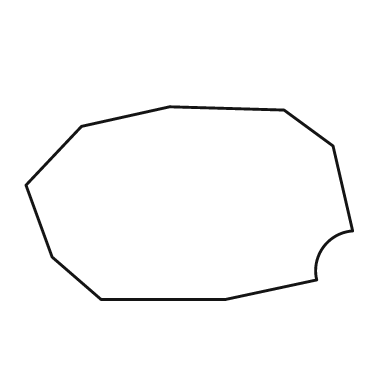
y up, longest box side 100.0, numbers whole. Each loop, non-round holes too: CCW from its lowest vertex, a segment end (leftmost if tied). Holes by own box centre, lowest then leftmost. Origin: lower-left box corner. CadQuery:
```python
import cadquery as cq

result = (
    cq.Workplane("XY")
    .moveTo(23.0, 0.0)
    .lineTo(61.0, 0.0)
    .lineTo(89.0, 6.0)
    .threePointArc((91.0, 16.0), (100.0, 21.0))
    .lineTo(94.0, 47.0)
    .lineTo(79.0, 58.0)
    .lineTo(44.0, 59.0)
    .lineTo(17.0, 53.0)
    .lineTo(0.0, 35.0)
    .lineTo(8.0, 13.0)
    .close()
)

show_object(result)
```